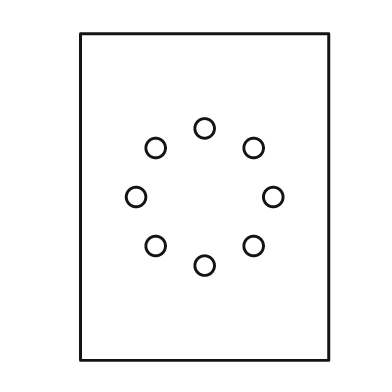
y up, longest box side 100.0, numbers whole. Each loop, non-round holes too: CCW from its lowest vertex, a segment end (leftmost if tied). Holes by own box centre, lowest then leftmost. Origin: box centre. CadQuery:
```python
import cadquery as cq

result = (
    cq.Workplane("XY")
    .moveTo(-38.0, -50.0)
    .lineTo(38.0, -50.0)
    .lineTo(38.0, 50.0)
    .lineTo(-38.0, 50.0)
    .close()
    .moveTo(0.0, -21.0)
    .circle(3.0)
    .moveTo(-15.0, -15.0)
    .circle(3.0)
    .moveTo(15.0, -15.0)
    .circle(3.0)
    .moveTo(-21.0, 0.0)
    .circle(3.0)
    .moveTo(21.0, 0.0)
    .circle(3.0)
    .moveTo(-15.0, 15.0)
    .circle(3.0)
    .moveTo(15.0, 15.0)
    .circle(3.0)
    .moveTo(0.0, 21.0)
    .circle(3.0)
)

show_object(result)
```